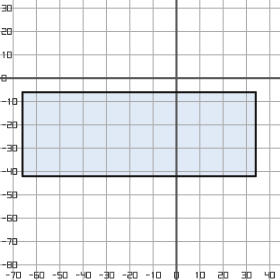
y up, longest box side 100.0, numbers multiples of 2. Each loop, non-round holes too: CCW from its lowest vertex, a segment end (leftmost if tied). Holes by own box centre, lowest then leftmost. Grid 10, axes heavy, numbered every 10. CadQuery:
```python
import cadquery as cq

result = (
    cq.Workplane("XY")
    .moveTo(-66.0, -42.0)
    .lineTo(34.0, -42.0)
    .lineTo(34.0, -6.0)
    .lineTo(-66.0, -6.0)
    .close()
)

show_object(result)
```